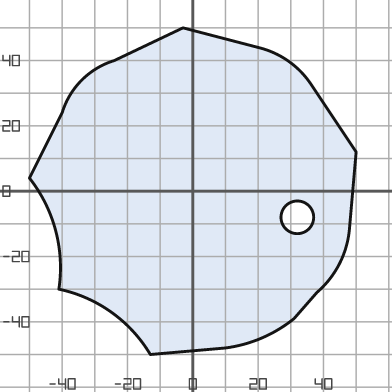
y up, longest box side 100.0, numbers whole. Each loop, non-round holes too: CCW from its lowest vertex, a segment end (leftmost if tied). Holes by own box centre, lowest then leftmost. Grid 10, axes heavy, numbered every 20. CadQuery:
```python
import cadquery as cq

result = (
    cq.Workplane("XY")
    .moveTo(-13.0, -50.0)
    .lineTo(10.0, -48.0)
    .threePointArc((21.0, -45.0), (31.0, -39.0))
    .lineTo(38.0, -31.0)
    .threePointArc((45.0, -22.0), (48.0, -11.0))
    .lineTo(50.0, 12.0)
    .lineTo(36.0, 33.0)
    .threePointArc((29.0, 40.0), (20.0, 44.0))
    .lineTo(-3.0, 50.0)
    .lineTo(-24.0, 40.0)
    .threePointArc((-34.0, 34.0), (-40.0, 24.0))
    .lineTo(-50.0, 4.0)
    .threePointArc((-42.0, -12.0), (-41.0, -30.0))
    .threePointArc((-25.0, -37.0), (-13.0, -50.0))
    .close()
    .moveTo(32.0, -8.0)
    .circle(5.0)
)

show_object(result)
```